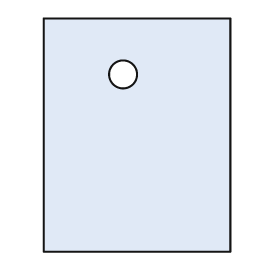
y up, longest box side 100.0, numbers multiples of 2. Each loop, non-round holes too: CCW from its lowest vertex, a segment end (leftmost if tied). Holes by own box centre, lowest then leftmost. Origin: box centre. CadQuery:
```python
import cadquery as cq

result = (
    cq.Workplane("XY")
    .moveTo(-40.0, -50.0)
    .lineTo(40.0, -50.0)
    .lineTo(40.0, 50.0)
    .lineTo(-40.0, 50.0)
    .close()
    .moveTo(-6.0, 26.0)
    .circle(6.0)
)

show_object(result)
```